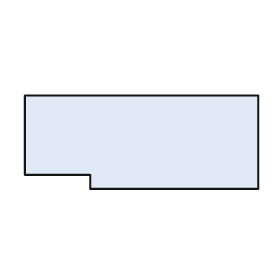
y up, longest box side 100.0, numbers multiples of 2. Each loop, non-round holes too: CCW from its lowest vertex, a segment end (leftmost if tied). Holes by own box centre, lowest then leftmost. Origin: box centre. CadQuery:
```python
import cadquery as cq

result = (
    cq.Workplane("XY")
    .moveTo(-22.0, -20.0)
    .lineTo(50.0, -20.0)
    .lineTo(50.0, 20.0)
    .lineTo(-50.0, 20.0)
    .lineTo(-50.0, -14.0)
    .lineTo(-22.0, -14.0)
    .close()
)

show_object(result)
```